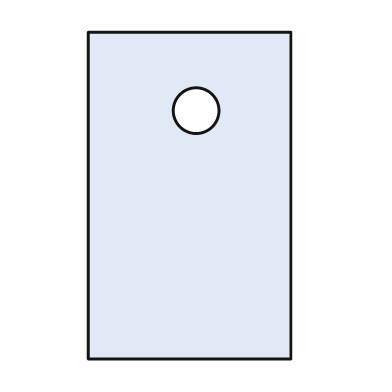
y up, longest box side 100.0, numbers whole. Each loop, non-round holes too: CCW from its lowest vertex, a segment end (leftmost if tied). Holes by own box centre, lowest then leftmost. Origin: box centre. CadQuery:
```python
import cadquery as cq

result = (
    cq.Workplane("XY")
    .moveTo(-31.0, -50.0)
    .lineTo(31.0, -50.0)
    .lineTo(31.0, 50.0)
    .lineTo(-31.0, 50.0)
    .close()
    .moveTo(2.0, 26.0)
    .circle(7.0)
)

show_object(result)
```